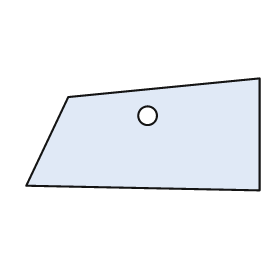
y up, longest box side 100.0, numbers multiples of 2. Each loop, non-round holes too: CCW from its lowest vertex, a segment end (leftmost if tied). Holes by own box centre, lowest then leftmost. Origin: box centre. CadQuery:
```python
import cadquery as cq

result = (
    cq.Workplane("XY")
    .moveTo(50.0, -24.0)
    .lineTo(50.0, 24.0)
    .lineTo(-32.0, 16.0)
    .lineTo(-50.0, -22.0)
    .close()
    .moveTo(2.0, 8.0)
    .circle(4.0)
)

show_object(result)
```